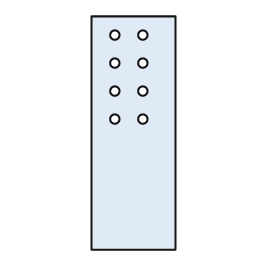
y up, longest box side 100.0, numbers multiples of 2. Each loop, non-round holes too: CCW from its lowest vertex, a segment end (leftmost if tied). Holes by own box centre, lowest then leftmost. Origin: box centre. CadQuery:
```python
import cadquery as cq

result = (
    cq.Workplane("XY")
    .moveTo(-18.0, -50.0)
    .lineTo(18.0, -50.0)
    .lineTo(18.0, 50.0)
    .lineTo(-18.0, 50.0)
    .close()
    .moveTo(-8.0, 6.0)
    .circle(2.0)
    .moveTo(4.0, 6.0)
    .circle(2.0)
    .moveTo(-8.0, 18.0)
    .circle(2.0)
    .moveTo(4.0, 18.0)
    .circle(2.0)
    .moveTo(-8.0, 30.0)
    .circle(2.0)
    .moveTo(4.0, 30.0)
    .circle(2.0)
    .moveTo(-8.0, 42.0)
    .circle(2.0)
    .moveTo(4.0, 42.0)
    .circle(2.0)
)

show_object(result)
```